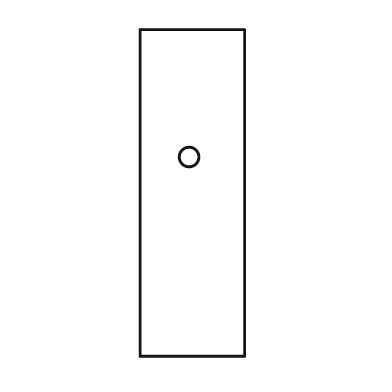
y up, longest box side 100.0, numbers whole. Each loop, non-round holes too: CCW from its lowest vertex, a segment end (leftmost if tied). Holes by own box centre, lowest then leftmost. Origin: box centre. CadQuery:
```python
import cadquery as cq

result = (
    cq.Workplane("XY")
    .moveTo(-16.0, -50.0)
    .lineTo(16.0, -50.0)
    .lineTo(16.0, 50.0)
    .lineTo(-16.0, 50.0)
    .close()
    .moveTo(-1.0, 11.0)
    .circle(3.0)
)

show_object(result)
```